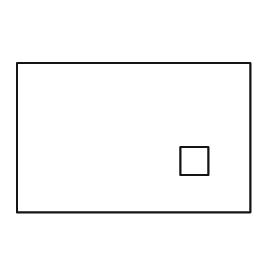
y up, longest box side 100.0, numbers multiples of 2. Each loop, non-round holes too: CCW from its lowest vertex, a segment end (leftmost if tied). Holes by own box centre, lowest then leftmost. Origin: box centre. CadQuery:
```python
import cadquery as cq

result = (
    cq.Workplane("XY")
    .moveTo(-50.0, -32.0)
    .lineTo(50.0, -32.0)
    .lineTo(50.0, 32.0)
    .lineTo(-50.0, 32.0)
    .close()
    .moveTo(20.0, -16.0)
    .lineTo(32.0, -16.0)
    .lineTo(32.0, -4.0)
    .lineTo(20.0, -4.0)
    .close()
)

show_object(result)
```